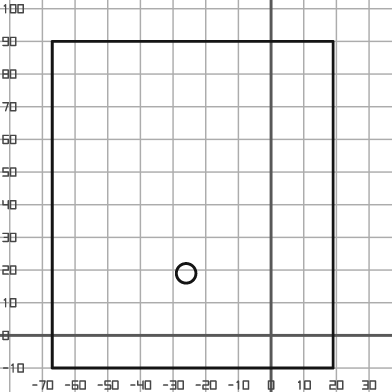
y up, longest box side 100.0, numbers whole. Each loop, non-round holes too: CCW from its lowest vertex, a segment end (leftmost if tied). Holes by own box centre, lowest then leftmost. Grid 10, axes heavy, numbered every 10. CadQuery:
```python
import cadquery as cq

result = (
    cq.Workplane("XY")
    .moveTo(-67.0, -10.0)
    .lineTo(19.0, -10.0)
    .lineTo(19.0, 90.0)
    .lineTo(-67.0, 90.0)
    .close()
    .moveTo(-26.0, 19.0)
    .circle(3.0)
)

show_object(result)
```